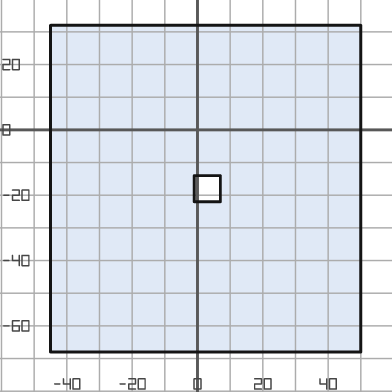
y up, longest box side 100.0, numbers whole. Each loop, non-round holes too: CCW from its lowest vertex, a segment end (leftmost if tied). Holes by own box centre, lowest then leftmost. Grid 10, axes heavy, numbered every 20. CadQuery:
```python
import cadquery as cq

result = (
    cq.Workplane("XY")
    .moveTo(-45.0, -68.0)
    .lineTo(50.0, -68.0)
    .lineTo(50.0, 32.0)
    .lineTo(-45.0, 32.0)
    .close()
    .moveTo(-1.0, -22.0)
    .lineTo(7.0, -22.0)
    .lineTo(7.0, -14.0)
    .lineTo(-1.0, -14.0)
    .close()
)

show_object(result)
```